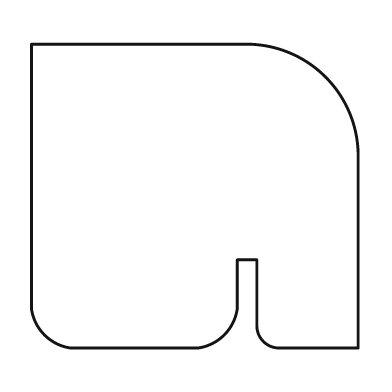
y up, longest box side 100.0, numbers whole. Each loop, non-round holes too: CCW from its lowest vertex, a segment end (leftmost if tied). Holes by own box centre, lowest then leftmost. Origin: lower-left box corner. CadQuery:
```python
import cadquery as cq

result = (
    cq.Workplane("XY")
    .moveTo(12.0, 0.0)
    .lineTo(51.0, 0.0)
    .threePointArc((59.0, 4.0), (63.0, 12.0))
    .lineTo(63.0, 27.0)
    .lineTo(69.0, 27.0)
    .lineTo(69.0, 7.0)
    .threePointArc((71.0, 2.0), (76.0, 0.0))
    .lineTo(100.0, 0.0)
    .lineTo(100.0, 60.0)
    .threePointArc((90.0, 83.0), (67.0, 93.0))
    .lineTo(0.0, 93.0)
    .lineTo(0.0, 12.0)
    .threePointArc((4.0, 4.0), (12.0, 0.0))
    .close()
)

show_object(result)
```